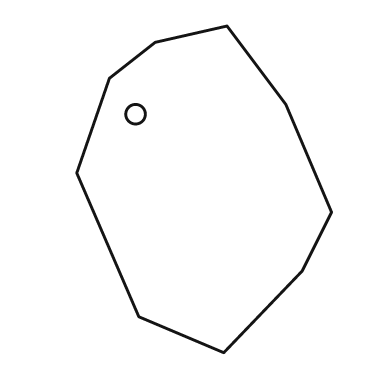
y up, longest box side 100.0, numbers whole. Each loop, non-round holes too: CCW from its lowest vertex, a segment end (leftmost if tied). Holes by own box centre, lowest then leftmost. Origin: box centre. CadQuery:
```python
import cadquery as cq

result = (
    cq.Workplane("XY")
    .moveTo(6.0, -50.0)
    .lineTo(30.0, -25.0)
    .lineTo(39.0, -7.0)
    .lineTo(25.0, 26.0)
    .lineTo(7.0, 50.0)
    .lineTo(-15.0, 45.0)
    .lineTo(-29.0, 34.0)
    .lineTo(-39.0, 5.0)
    .lineTo(-20.0, -39.0)
    .close()
    .moveTo(-21.0, 23.0)
    .circle(3.0)
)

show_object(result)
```